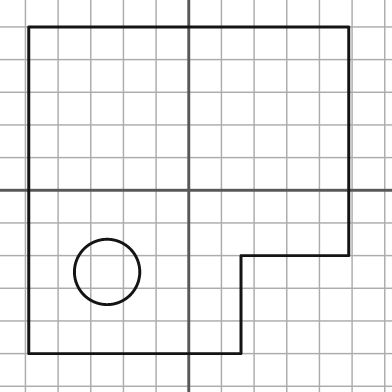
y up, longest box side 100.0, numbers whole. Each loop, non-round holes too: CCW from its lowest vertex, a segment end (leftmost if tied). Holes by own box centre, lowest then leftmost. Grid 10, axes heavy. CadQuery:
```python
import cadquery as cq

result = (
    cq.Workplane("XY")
    .moveTo(-49.0, -50.0)
    .lineTo(16.0, -50.0)
    .lineTo(16.0, -20.0)
    .lineTo(49.0, -20.0)
    .lineTo(49.0, 50.0)
    .lineTo(-49.0, 50.0)
    .close()
    .moveTo(-25.0, -25.0)
    .circle(10.0)
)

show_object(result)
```